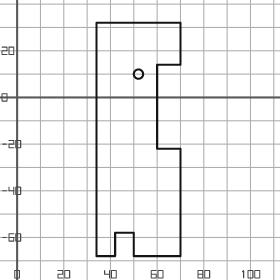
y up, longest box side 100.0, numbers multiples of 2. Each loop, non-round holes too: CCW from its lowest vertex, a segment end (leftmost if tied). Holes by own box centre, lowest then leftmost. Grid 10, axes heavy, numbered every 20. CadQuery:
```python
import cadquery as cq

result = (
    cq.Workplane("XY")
    .moveTo(34.0, -68.0)
    .lineTo(42.0, -68.0)
    .lineTo(42.0, -58.0)
    .lineTo(50.0, -58.0)
    .lineTo(50.0, -68.0)
    .lineTo(70.0, -68.0)
    .lineTo(70.0, -22.0)
    .lineTo(60.0, -22.0)
    .lineTo(60.0, 14.0)
    .lineTo(70.0, 14.0)
    .lineTo(70.0, 32.0)
    .lineTo(34.0, 32.0)
    .close()
    .moveTo(52.0, 10.0)
    .circle(2.0)
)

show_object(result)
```